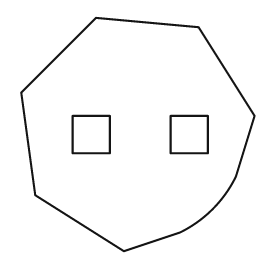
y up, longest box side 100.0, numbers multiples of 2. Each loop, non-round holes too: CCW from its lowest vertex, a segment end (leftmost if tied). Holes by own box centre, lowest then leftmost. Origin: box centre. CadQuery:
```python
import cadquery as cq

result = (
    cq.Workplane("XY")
    .moveTo(-6.0, -50.0)
    .lineTo(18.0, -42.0)
    .threePointArc((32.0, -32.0), (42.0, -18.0))
    .lineTo(50.0, 8.0)
    .lineTo(26.0, 46.0)
    .lineTo(-18.0, 50.0)
    .lineTo(-50.0, 18.0)
    .lineTo(-44.0, -26.0)
    .close()
    .moveTo(-28.0, -8.0)
    .lineTo(-12.0, -8.0)
    .lineTo(-12.0, 8.0)
    .lineTo(-28.0, 8.0)
    .close()
    .moveTo(14.0, -8.0)
    .lineTo(30.0, -8.0)
    .lineTo(30.0, 8.0)
    .lineTo(14.0, 8.0)
    .close()
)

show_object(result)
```